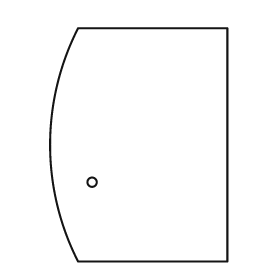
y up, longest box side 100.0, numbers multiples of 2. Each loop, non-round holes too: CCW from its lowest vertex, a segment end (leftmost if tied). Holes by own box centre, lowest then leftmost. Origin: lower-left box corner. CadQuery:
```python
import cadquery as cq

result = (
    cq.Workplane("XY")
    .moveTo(12.0, 0.0)
    .lineTo(76.0, 0.0)
    .lineTo(76.0, 100.0)
    .lineTo(12.0, 100.0)
    .threePointArc((0.0, 50.0), (12.0, 0.0))
    .close()
    .moveTo(18.0, 34.0)
    .circle(2.0)
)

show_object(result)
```